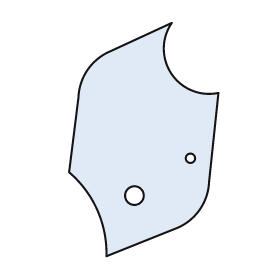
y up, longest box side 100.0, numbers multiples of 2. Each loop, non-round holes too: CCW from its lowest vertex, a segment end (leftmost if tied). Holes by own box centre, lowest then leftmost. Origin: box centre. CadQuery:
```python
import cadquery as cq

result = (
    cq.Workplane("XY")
    .moveTo(-16.0, -50.0)
    .lineTo(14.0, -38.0)
    .threePointArc((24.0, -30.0), (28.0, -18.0))
    .lineTo(32.0, 20.0)
    .threePointArc((12.0, 28.0), (12.0, 50.0))
    .lineTo(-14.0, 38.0)
    .threePointArc((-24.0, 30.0), (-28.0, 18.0))
    .lineTo(-32.0, -14.0)
    .threePointArc((-20.0, -30.0), (-16.0, -50.0))
    .close()
    .moveTo(-4.0, -24.0)
    .circle(4.0)
    .moveTo(20.0, -8.0)
    .circle(2.0)
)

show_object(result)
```